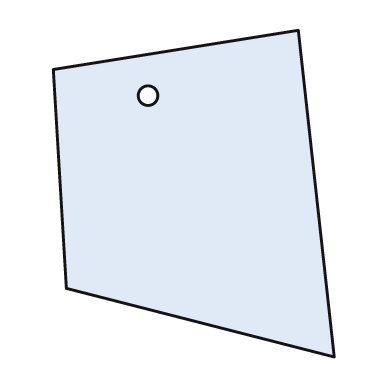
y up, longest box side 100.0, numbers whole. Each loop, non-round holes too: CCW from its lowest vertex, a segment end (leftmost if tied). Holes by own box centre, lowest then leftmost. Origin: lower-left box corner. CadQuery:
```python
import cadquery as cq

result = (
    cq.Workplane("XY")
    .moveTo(86.0, 0.0)
    .lineTo(75.0, 100.0)
    .lineTo(0.0, 88.0)
    .lineTo(4.0, 21.0)
    .close()
    .moveTo(29.0, 80.0)
    .circle(3.0)
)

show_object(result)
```